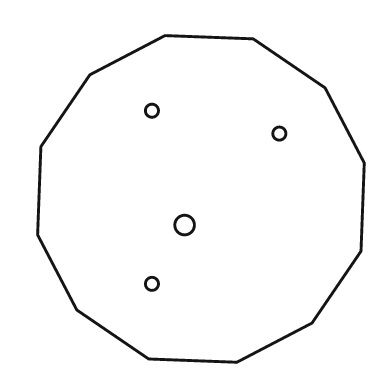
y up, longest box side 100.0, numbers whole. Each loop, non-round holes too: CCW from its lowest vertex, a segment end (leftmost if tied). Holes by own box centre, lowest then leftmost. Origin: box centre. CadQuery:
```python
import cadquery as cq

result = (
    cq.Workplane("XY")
    .moveTo(11.0, -50.0)
    .lineTo(34.0, -38.0)
    .lineTo(49.0, -16.0)
    .lineTo(50.0, 11.0)
    .lineTo(38.0, 34.0)
    .lineTo(16.0, 49.0)
    .lineTo(-11.0, 50.0)
    .lineTo(-34.0, 38.0)
    .lineTo(-49.0, 16.0)
    .lineTo(-50.0, -11.0)
    .lineTo(-38.0, -34.0)
    .lineTo(-16.0, -49.0)
    .close()
    .moveTo(-15.0, -26.0)
    .circle(2.0)
    .moveTo(-5.0, -8.0)
    .circle(3.0)
    .moveTo(24.0, 20.0)
    .circle(2.0)
    .moveTo(-15.0, 27.0)
    .circle(2.0)
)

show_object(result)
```